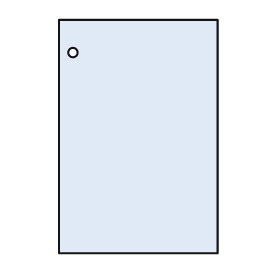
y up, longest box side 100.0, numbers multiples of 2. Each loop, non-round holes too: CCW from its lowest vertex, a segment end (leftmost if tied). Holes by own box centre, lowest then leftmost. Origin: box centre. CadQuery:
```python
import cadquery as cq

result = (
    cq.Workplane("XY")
    .moveTo(-34.0, -50.0)
    .lineTo(34.0, -50.0)
    .lineTo(34.0, 50.0)
    .lineTo(-34.0, 50.0)
    .close()
    .moveTo(-28.0, 36.0)
    .circle(2.0)
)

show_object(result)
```